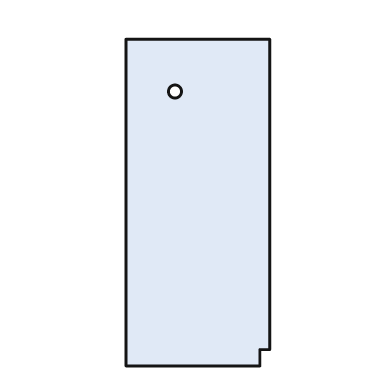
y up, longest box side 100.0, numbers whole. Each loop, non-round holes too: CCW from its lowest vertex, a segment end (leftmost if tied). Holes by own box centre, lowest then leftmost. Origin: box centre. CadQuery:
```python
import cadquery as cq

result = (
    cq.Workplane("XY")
    .moveTo(-22.0, -50.0)
    .lineTo(19.0, -50.0)
    .lineTo(19.0, -45.0)
    .lineTo(22.0, -45.0)
    .lineTo(22.0, 50.0)
    .lineTo(-22.0, 50.0)
    .close()
    .moveTo(-7.0, 34.0)
    .circle(2.0)
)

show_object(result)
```